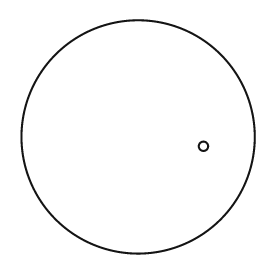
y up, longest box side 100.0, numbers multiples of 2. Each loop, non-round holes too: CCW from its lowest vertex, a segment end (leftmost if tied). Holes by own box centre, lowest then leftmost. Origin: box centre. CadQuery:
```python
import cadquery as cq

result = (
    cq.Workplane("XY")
    .moveTo(0.0, 0.0)
    .circle(50.0)
    .moveTo(28.0, -4.0)
    .circle(2.0)
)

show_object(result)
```